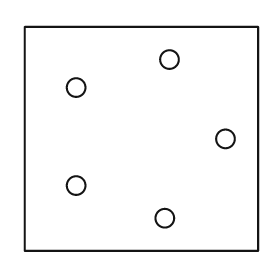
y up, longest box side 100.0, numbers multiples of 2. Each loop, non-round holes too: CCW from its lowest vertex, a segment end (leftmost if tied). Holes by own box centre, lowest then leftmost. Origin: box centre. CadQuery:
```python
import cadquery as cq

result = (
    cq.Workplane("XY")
    .moveTo(-50.0, -48.0)
    .lineTo(50.0, -48.0)
    .lineTo(50.0, 48.0)
    .lineTo(-50.0, 48.0)
    .close()
    .moveTo(10.0, -34.0)
    .circle(4.0)
    .moveTo(-28.0, -20.0)
    .circle(4.0)
    .moveTo(36.0, 0.0)
    .circle(4.0)
    .moveTo(-28.0, 22.0)
    .circle(4.0)
    .moveTo(12.0, 34.0)
    .circle(4.0)
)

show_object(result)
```